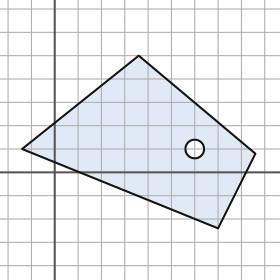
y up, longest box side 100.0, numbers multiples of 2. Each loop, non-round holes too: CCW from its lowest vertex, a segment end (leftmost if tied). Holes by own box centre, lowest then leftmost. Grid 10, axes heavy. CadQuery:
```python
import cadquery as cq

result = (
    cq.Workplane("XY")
    .moveTo(70.0, -24.0)
    .lineTo(86.0, 8.0)
    .lineTo(36.0, 50.0)
    .lineTo(-14.0, 10.0)
    .close()
    .moveTo(60.0, 10.0)
    .circle(4.0)
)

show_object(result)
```